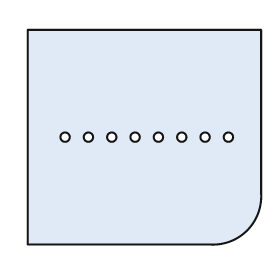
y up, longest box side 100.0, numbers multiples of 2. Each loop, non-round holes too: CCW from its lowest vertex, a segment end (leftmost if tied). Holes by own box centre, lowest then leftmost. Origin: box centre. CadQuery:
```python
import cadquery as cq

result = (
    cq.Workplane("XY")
    .moveTo(-50.0, -46.0)
    .lineTo(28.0, -46.0)
    .threePointArc((44.0, -40.0), (50.0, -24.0))
    .lineTo(50.0, 46.0)
    .lineTo(-50.0, 46.0)
    .close()
    .moveTo(-34.0, 0.0)
    .circle(2.0)
    .moveTo(-24.0, 0.0)
    .circle(2.0)
    .moveTo(-14.0, 0.0)
    .circle(2.0)
    .moveTo(-4.0, 0.0)
    .circle(2.0)
    .moveTo(6.0, 0.0)
    .circle(2.0)
    .moveTo(16.0, 0.0)
    .circle(2.0)
    .moveTo(26.0, 0.0)
    .circle(2.0)
    .moveTo(36.0, 0.0)
    .circle(2.0)
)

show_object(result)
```